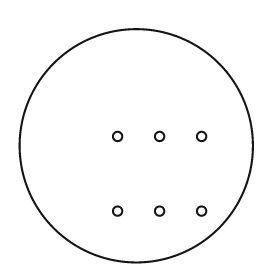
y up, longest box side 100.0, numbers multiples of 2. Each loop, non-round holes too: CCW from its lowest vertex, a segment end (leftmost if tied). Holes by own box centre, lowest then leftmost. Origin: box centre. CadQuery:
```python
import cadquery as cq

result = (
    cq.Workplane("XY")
    .moveTo(0.0, 0.0)
    .circle(50.0)
    .moveTo(-8.0, -28.0)
    .circle(2.0)
    .moveTo(10.0, -28.0)
    .circle(2.0)
    .moveTo(28.0, -28.0)
    .circle(2.0)
    .moveTo(-8.0, 4.0)
    .circle(2.0)
    .moveTo(10.0, 4.0)
    .circle(2.0)
    .moveTo(28.0, 4.0)
    .circle(2.0)
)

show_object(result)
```